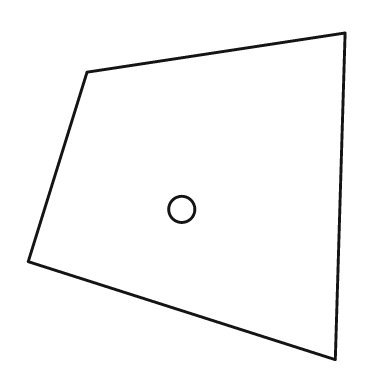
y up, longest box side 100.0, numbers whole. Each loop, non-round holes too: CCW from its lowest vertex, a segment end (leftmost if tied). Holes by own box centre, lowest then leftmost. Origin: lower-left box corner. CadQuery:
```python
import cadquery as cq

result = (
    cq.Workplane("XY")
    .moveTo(94.0, 0.0)
    .lineTo(97.0, 100.0)
    .lineTo(18.0, 88.0)
    .lineTo(0.0, 30.0)
    .close()
    .moveTo(47.0, 46.0)
    .circle(4.0)
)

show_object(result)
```